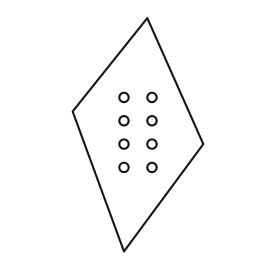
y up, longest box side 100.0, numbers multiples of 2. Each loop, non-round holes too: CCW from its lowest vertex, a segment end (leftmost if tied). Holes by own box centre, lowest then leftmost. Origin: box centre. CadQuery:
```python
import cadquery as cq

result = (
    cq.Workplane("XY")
    .moveTo(-6.0, -50.0)
    .lineTo(28.0, -4.0)
    .lineTo(4.0, 50.0)
    .lineTo(-28.0, 10.0)
    .close()
    .moveTo(-6.0, -14.0)
    .circle(2.0)
    .moveTo(6.0, -14.0)
    .circle(2.0)
    .moveTo(-6.0, -4.0)
    .circle(2.0)
    .moveTo(6.0, -4.0)
    .circle(2.0)
    .moveTo(-6.0, 6.0)
    .circle(2.0)
    .moveTo(6.0, 6.0)
    .circle(2.0)
    .moveTo(-6.0, 16.0)
    .circle(2.0)
    .moveTo(6.0, 16.0)
    .circle(2.0)
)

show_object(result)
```